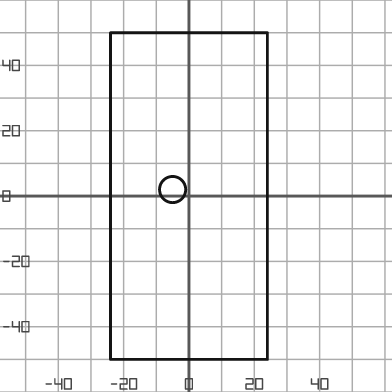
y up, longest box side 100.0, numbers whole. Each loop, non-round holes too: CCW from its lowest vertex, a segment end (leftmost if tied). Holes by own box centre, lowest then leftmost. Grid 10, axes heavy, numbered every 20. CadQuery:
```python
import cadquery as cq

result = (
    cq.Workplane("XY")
    .moveTo(-24.0, -50.0)
    .lineTo(24.0, -50.0)
    .lineTo(24.0, 50.0)
    .lineTo(-24.0, 50.0)
    .close()
    .moveTo(-5.0, 2.0)
    .circle(4.0)
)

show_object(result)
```